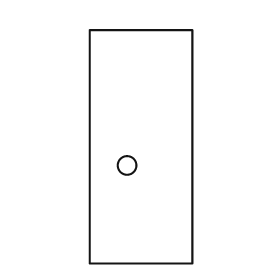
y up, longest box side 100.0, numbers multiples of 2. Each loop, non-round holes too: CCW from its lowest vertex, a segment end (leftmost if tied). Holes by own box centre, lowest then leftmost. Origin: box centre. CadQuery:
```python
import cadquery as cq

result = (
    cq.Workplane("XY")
    .moveTo(-22.0, -50.0)
    .lineTo(22.0, -50.0)
    .lineTo(22.0, 50.0)
    .lineTo(-22.0, 50.0)
    .close()
    .moveTo(-6.0, -8.0)
    .circle(4.0)
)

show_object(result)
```